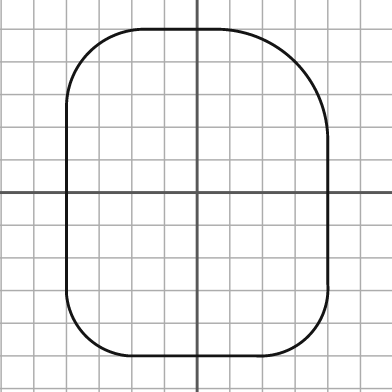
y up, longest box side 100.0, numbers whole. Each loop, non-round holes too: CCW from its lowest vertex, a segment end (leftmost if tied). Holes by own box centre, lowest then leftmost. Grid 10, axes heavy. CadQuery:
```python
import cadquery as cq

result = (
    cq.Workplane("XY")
    .moveTo(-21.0, -50.0)
    .lineTo(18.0, -50.0)
    .threePointArc((34.0, -44.0), (40.0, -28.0))
    .lineTo(40.0, 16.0)
    .threePointArc((30.0, 40.0), (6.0, 50.0))
    .lineTo(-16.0, 50.0)
    .threePointArc((-33.0, 43.0), (-40.0, 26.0))
    .lineTo(-40.0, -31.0)
    .threePointArc((-34.0, -44.0), (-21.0, -50.0))
    .close()
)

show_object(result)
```